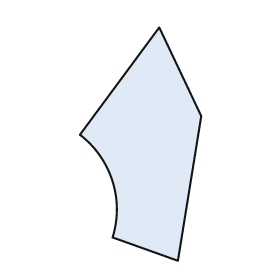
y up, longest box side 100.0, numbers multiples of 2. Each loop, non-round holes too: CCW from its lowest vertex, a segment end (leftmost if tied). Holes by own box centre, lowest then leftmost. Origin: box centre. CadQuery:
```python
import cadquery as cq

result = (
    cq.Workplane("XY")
    .moveTo(16.0, -50.0)
    .lineTo(26.0, 12.0)
    .lineTo(8.0, 50.0)
    .lineTo(-26.0, 4.0)
    .threePointArc((-12.0, -16.0), (-12.0, -40.0))
    .close()
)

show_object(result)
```